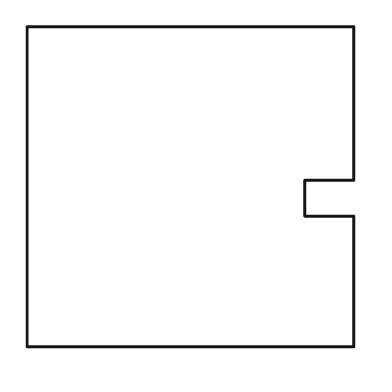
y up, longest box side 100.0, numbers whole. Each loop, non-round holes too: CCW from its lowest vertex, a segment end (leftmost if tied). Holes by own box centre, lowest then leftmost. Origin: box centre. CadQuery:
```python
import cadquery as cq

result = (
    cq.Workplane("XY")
    .moveTo(-50.0, -49.0)
    .lineTo(50.0, -49.0)
    .lineTo(50.0, -9.0)
    .lineTo(35.0, -9.0)
    .lineTo(35.0, 2.0)
    .lineTo(50.0, 2.0)
    .lineTo(50.0, 49.0)
    .lineTo(-50.0, 49.0)
    .close()
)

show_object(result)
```